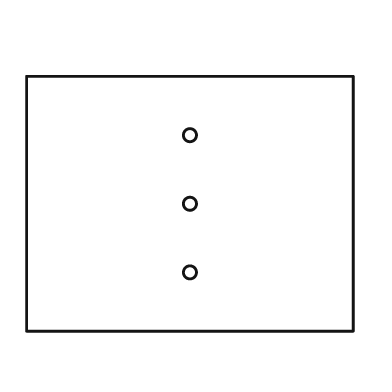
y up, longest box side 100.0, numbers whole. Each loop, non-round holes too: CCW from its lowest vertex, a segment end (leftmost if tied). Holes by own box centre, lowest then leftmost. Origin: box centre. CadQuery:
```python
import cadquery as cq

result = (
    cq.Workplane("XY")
    .moveTo(-50.0, -39.0)
    .lineTo(50.0, -39.0)
    .lineTo(50.0, 39.0)
    .lineTo(-50.0, 39.0)
    .close()
    .moveTo(0.0, -21.0)
    .circle(2.0)
    .moveTo(0.0, 0.0)
    .circle(2.0)
    .moveTo(0.0, 21.0)
    .circle(2.0)
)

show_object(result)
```